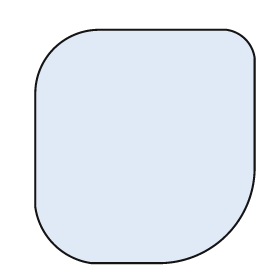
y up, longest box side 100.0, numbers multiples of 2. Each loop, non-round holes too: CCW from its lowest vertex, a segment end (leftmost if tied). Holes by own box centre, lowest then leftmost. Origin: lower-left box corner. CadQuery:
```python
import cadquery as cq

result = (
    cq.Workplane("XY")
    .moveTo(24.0, 0.0)
    .lineTo(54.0, 0.0)
    .threePointArc((82.0, 12.0), (94.0, 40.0))
    .lineTo(94.0, 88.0)
    .threePointArc((90.0, 96.0), (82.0, 100.0))
    .lineTo(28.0, 100.0)
    .threePointArc((8.0, 92.0), (0.0, 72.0))
    .lineTo(0.0, 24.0)
    .threePointArc((8.0, 8.0), (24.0, 0.0))
    .close()
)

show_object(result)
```